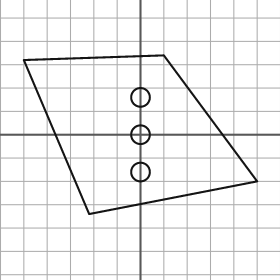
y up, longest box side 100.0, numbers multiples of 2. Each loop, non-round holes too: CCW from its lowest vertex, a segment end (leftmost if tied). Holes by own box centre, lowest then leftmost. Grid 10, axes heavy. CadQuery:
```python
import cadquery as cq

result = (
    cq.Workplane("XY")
    .moveTo(-22.0, -34.0)
    .lineTo(50.0, -20.0)
    .lineTo(10.0, 34.0)
    .lineTo(-50.0, 32.0)
    .close()
    .moveTo(0.0, -16.0)
    .circle(4.0)
    .moveTo(0.0, 0.0)
    .circle(4.0)
    .moveTo(0.0, 16.0)
    .circle(4.0)
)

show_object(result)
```